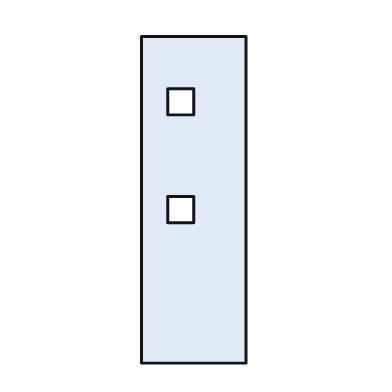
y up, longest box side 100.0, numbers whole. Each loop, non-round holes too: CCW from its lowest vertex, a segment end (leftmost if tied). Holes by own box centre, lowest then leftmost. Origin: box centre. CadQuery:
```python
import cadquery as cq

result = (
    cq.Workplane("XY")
    .moveTo(-16.0, -50.0)
    .lineTo(16.0, -50.0)
    .lineTo(16.0, 50.0)
    .lineTo(-16.0, 50.0)
    .close()
    .moveTo(-8.0, -7.0)
    .lineTo(0.0, -7.0)
    .lineTo(0.0, 1.0)
    .lineTo(-8.0, 1.0)
    .close()
    .moveTo(-8.0, 26.0)
    .lineTo(0.0, 26.0)
    .lineTo(0.0, 34.0)
    .lineTo(-8.0, 34.0)
    .close()
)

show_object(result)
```